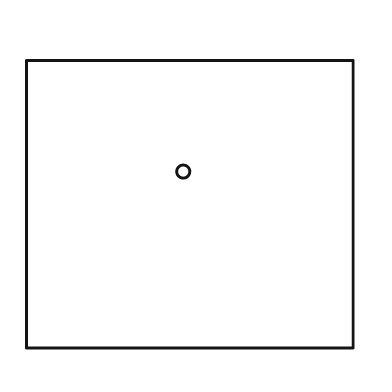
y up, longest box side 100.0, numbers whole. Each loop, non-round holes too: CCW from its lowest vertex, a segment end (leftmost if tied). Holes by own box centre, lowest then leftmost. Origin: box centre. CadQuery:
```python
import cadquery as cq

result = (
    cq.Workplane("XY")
    .moveTo(-50.0, -44.0)
    .lineTo(50.0, -44.0)
    .lineTo(50.0, 44.0)
    .lineTo(-50.0, 44.0)
    .close()
    .moveTo(-2.0, 10.0)
    .circle(2.0)
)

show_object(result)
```